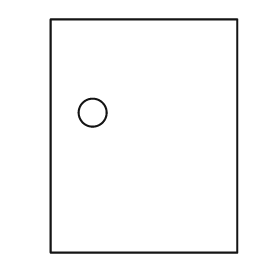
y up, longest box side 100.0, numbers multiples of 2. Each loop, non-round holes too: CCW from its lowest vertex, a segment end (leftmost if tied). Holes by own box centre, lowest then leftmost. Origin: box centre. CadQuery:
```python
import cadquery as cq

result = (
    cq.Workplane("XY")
    .moveTo(-40.0, -50.0)
    .lineTo(40.0, -50.0)
    .lineTo(40.0, 50.0)
    .lineTo(-40.0, 50.0)
    .close()
    .moveTo(-22.0, 10.0)
    .circle(6.0)
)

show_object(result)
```